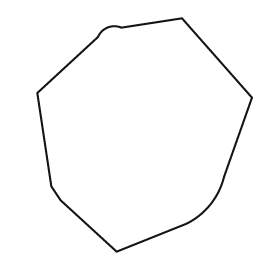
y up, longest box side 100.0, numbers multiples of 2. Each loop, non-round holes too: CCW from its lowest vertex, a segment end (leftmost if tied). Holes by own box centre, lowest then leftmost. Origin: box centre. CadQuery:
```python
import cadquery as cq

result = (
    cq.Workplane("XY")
    .moveTo(-12.0, -50.0)
    .lineTo(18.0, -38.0)
    .threePointArc((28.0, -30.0), (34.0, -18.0))
    .lineTo(46.0, 16.0)
    .lineTo(16.0, 50.0)
    .lineTo(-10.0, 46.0)
    .threePointArc((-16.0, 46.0), (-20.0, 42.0))
    .lineTo(-46.0, 18.0)
    .lineTo(-40.0, -22.0)
    .lineTo(-36.0, -28.0)
    .close()
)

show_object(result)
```